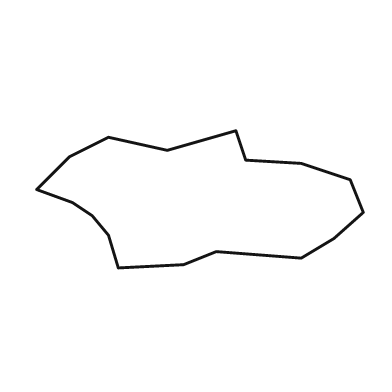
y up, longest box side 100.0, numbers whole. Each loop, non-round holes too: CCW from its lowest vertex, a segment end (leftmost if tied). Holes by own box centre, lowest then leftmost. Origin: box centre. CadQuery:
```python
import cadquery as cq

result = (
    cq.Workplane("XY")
    .moveTo(-25.0, -21.0)
    .lineTo(-5.0, -20.0)
    .lineTo(5.0, -16.0)
    .lineTo(31.0, -18.0)
    .lineTo(41.0, -12.0)
    .lineTo(50.0, -4.0)
    .lineTo(46.0, 6.0)
    .lineTo(31.0, 11.0)
    .lineTo(14.0, 12.0)
    .lineTo(11.0, 21.0)
    .lineTo(-10.0, 15.0)
    .lineTo(-28.0, 19.0)
    .lineTo(-40.0, 13.0)
    .lineTo(-50.0, 3.0)
    .lineTo(-39.0, -1.0)
    .lineTo(-33.0, -5.0)
    .lineTo(-28.0, -11.0)
    .close()
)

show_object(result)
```